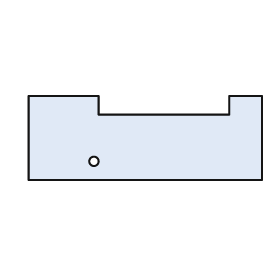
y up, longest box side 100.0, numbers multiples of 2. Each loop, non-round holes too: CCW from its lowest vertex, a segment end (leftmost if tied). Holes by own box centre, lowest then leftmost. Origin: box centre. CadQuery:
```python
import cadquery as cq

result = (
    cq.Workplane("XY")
    .moveTo(-50.0, -18.0)
    .lineTo(50.0, -18.0)
    .lineTo(50.0, 18.0)
    .lineTo(36.0, 18.0)
    .lineTo(36.0, 10.0)
    .lineTo(-20.0, 10.0)
    .lineTo(-20.0, 18.0)
    .lineTo(-50.0, 18.0)
    .close()
    .moveTo(-22.0, -10.0)
    .circle(2.0)
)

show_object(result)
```